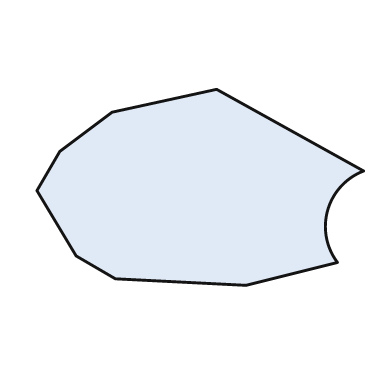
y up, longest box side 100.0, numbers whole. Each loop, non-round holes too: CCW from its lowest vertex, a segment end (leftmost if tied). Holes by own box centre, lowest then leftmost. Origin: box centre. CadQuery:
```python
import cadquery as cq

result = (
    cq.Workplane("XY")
    .moveTo(14.0, -30.0)
    .lineTo(42.0, -23.0)
    .threePointArc((39.0, -7.0), (50.0, 5.0))
    .lineTo(5.0, 30.0)
    .lineTo(-27.0, 23.0)
    .lineTo(-43.0, 11.0)
    .lineTo(-50.0, -1.0)
    .lineTo(-38.0, -21.0)
    .lineTo(-26.0, -28.0)
    .close()
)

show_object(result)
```